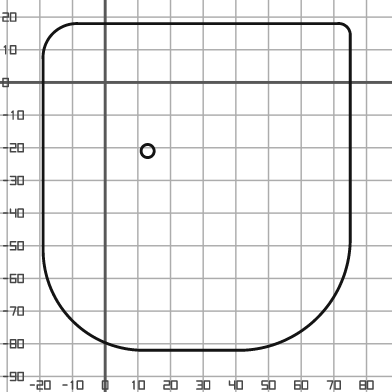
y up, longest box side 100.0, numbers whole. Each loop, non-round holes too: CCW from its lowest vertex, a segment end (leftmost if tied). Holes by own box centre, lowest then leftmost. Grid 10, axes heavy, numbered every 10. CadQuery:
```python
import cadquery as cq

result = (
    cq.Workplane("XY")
    .moveTo(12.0, -82.0)
    .lineTo(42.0, -82.0)
    .threePointArc((65.0, -72.0), (75.0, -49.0))
    .lineTo(75.0, 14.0)
    .threePointArc((74.0, 17.0), (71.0, 18.0))
    .lineTo(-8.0, 18.0)
    .threePointArc((-16.0, 15.0), (-19.0, 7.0))
    .lineTo(-19.0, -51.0)
    .threePointArc((-10.0, -73.0), (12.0, -82.0))
    .close()
    .moveTo(13.0, -21.0)
    .circle(2.0)
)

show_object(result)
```